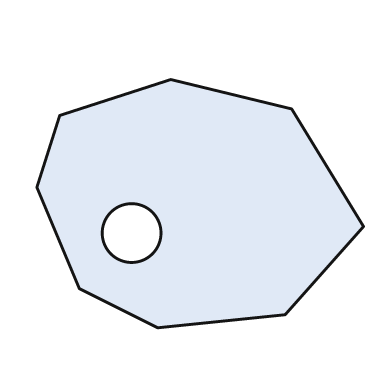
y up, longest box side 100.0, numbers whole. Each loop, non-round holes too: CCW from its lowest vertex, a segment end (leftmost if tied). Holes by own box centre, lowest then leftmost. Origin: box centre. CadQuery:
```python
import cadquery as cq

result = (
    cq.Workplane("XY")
    .moveTo(-13.0, -38.0)
    .lineTo(26.0, -34.0)
    .lineTo(50.0, -7.0)
    .lineTo(28.0, 29.0)
    .lineTo(-9.0, 38.0)
    .lineTo(-43.0, 27.0)
    .lineTo(-50.0, 5.0)
    .lineTo(-37.0, -26.0)
    .close()
    .moveTo(-21.0, -9.0)
    .circle(9.0)
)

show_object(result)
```